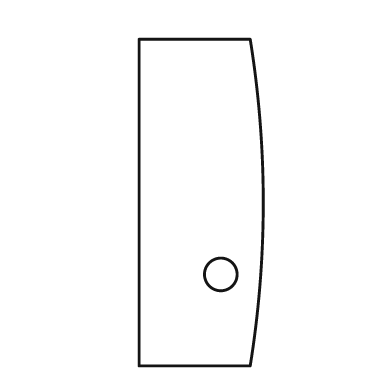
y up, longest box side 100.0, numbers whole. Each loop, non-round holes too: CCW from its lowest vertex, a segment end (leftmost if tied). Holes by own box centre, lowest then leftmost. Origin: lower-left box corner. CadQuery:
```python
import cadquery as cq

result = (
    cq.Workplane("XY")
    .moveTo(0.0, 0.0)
    .lineTo(34.0, 0.0)
    .threePointArc((38.0, 50.0), (34.0, 100.0))
    .lineTo(0.0, 100.0)
    .close()
    .moveTo(25.0, 28.0)
    .circle(5.0)
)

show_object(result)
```